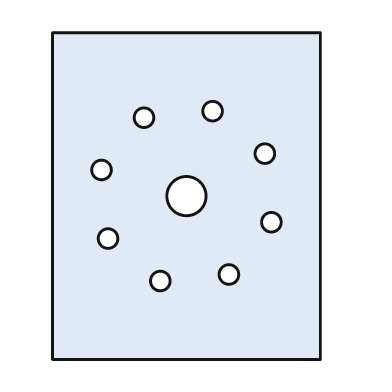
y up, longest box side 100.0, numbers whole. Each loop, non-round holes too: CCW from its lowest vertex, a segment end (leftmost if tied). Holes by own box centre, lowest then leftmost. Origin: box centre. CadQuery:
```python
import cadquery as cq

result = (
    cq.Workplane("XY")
    .moveTo(-41.0, -50.0)
    .lineTo(41.0, -50.0)
    .lineTo(41.0, 50.0)
    .lineTo(-41.0, 50.0)
    .close()
    .moveTo(-8.0, -26.0)
    .circle(3.0)
    .moveTo(13.0, -24.0)
    .circle(3.0)
    .moveTo(-24.0, -13.0)
    .circle(3.0)
    .moveTo(26.0, -8.0)
    .circle(3.0)
    .moveTo(0.0, 0.0)
    .circle(6.0)
    .moveTo(-26.0, 8.0)
    .circle(3.0)
    .moveTo(24.0, 13.0)
    .circle(3.0)
    .moveTo(-13.0, 24.0)
    .circle(3.0)
    .moveTo(8.0, 26.0)
    .circle(3.0)
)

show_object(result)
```